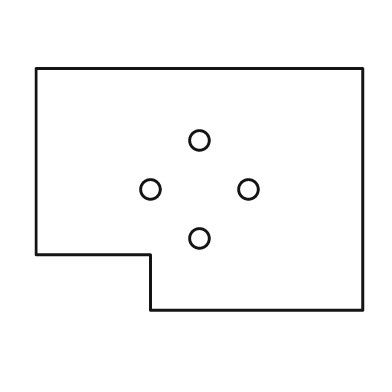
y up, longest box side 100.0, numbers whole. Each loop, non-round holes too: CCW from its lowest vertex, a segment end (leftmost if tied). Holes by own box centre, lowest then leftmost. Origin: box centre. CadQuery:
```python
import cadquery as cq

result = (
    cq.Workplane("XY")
    .moveTo(-15.0, -37.0)
    .lineTo(50.0, -37.0)
    .lineTo(50.0, 37.0)
    .lineTo(-50.0, 37.0)
    .lineTo(-50.0, -20.0)
    .lineTo(-15.0, -20.0)
    .close()
    .moveTo(0.0, -15.0)
    .circle(3.0)
    .moveTo(-15.0, 0.0)
    .circle(3.0)
    .moveTo(15.0, 0.0)
    .circle(3.0)
    .moveTo(0.0, 15.0)
    .circle(3.0)
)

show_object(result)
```